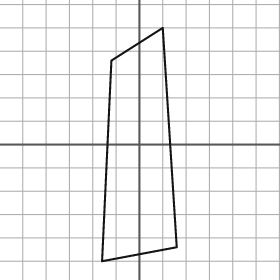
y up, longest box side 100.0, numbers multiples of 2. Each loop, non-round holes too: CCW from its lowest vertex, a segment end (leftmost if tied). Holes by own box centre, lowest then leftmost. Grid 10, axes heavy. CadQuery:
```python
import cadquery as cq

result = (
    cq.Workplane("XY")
    .moveTo(-16.0, -50.0)
    .lineTo(16.0, -44.0)
    .lineTo(10.0, 50.0)
    .lineTo(-12.0, 36.0)
    .close()
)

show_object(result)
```